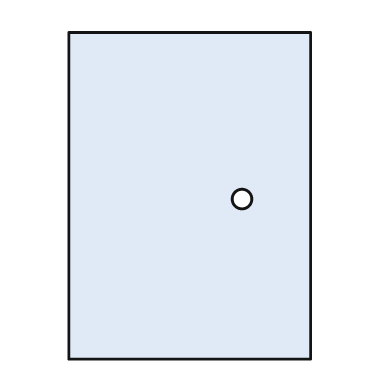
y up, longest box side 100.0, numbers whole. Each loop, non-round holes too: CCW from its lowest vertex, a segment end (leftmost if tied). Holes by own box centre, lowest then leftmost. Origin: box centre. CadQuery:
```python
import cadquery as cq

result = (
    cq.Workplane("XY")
    .moveTo(-37.0, -50.0)
    .lineTo(37.0, -50.0)
    .lineTo(37.0, 50.0)
    .lineTo(-37.0, 50.0)
    .close()
    .moveTo(16.0, -1.0)
    .circle(3.0)
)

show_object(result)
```